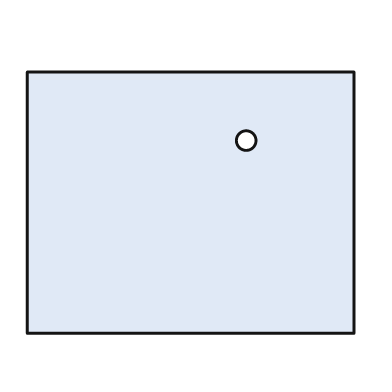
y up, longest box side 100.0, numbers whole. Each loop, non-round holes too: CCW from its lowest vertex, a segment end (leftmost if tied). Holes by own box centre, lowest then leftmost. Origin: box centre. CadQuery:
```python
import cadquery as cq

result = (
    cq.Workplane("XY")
    .moveTo(-50.0, -40.0)
    .lineTo(50.0, -40.0)
    .lineTo(50.0, 40.0)
    .lineTo(-50.0, 40.0)
    .close()
    .moveTo(17.0, 19.0)
    .circle(3.0)
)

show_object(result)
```